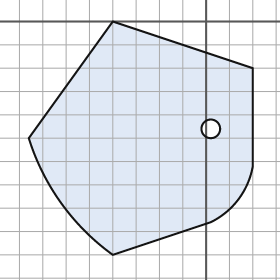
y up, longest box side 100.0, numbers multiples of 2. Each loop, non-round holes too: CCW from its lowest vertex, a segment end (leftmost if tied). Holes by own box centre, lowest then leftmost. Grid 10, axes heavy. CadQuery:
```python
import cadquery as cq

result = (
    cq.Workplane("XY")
    .moveTo(-40.0, -100.0)
    .lineTo(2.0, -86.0)
    .threePointArc((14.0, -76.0), (20.0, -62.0))
    .lineTo(20.0, -20.0)
    .lineTo(-40.0, 0.0)
    .lineTo(-76.0, -50.0)
    .threePointArc((-62.0, -78.0), (-40.0, -100.0))
    .close()
    .moveTo(2.0, -46.0)
    .circle(4.0)
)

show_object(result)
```